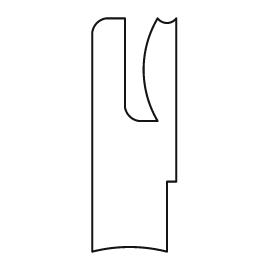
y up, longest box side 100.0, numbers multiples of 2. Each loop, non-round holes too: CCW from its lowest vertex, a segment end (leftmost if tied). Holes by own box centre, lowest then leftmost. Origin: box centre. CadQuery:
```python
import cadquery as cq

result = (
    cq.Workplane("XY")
    .moveTo(-18.0, -50.0)
    .threePointArc((-2.0, -48.0), (14.0, -50.0))
    .lineTo(14.0, -20.0)
    .lineTo(18.0, -20.0)
    .lineTo(18.0, 50.0)
    .threePointArc((14.0, 48.0), (10.0, 50.0))
    .threePointArc((4.0, 28.0), (10.0, 6.0))
    .lineTo(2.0, 6.0)
    .threePointArc((-2.0, 8.0), (-4.0, 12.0))
    .lineTo(-4.0, 50.0)
    .lineTo(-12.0, 50.0)
    .threePointArc((-16.0, 48.0), (-18.0, 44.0))
    .close()
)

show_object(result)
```